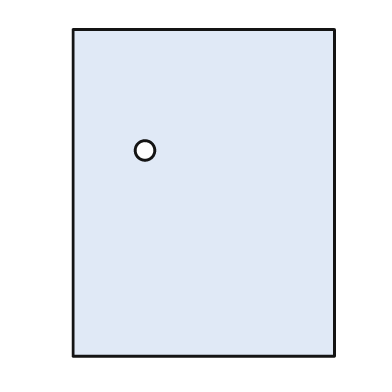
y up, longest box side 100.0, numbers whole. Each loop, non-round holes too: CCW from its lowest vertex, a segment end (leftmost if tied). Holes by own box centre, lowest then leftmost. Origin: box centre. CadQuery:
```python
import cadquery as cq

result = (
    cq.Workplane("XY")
    .moveTo(-40.0, -50.0)
    .lineTo(40.0, -50.0)
    .lineTo(40.0, 50.0)
    .lineTo(-40.0, 50.0)
    .close()
    .moveTo(-18.0, 13.0)
    .circle(3.0)
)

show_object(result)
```